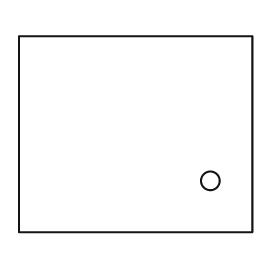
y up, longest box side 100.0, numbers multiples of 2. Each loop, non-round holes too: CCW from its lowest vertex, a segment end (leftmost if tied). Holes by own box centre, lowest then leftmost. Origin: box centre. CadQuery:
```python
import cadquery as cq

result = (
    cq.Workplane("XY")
    .moveTo(-50.0, -42.0)
    .lineTo(50.0, -42.0)
    .lineTo(50.0, 42.0)
    .lineTo(-50.0, 42.0)
    .close()
    .moveTo(32.0, -20.0)
    .circle(4.0)
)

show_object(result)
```